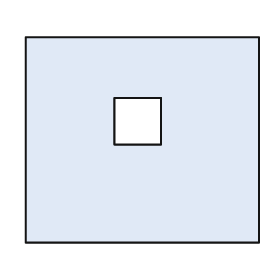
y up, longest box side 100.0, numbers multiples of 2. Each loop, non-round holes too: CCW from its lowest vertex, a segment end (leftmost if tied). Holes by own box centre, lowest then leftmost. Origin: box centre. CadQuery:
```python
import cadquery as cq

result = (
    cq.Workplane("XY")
    .moveTo(-50.0, -44.0)
    .lineTo(50.0, -44.0)
    .lineTo(50.0, 44.0)
    .lineTo(-50.0, 44.0)
    .close()
    .moveTo(-12.0, -2.0)
    .lineTo(8.0, -2.0)
    .lineTo(8.0, 18.0)
    .lineTo(-12.0, 18.0)
    .close()
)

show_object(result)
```